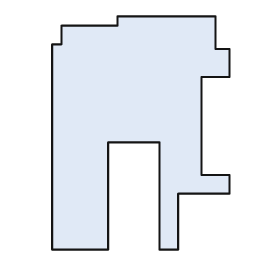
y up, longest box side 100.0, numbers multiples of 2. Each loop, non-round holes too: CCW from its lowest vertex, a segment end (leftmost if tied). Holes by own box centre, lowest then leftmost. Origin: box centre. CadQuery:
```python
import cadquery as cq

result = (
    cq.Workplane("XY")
    .moveTo(-38.0, -50.0)
    .lineTo(-14.0, -50.0)
    .lineTo(-14.0, -4.0)
    .lineTo(8.0, -4.0)
    .lineTo(8.0, -50.0)
    .lineTo(16.0, -50.0)
    .lineTo(16.0, -26.0)
    .lineTo(38.0, -26.0)
    .lineTo(38.0, -18.0)
    .lineTo(26.0, -18.0)
    .lineTo(26.0, 24.0)
    .lineTo(38.0, 24.0)
    .lineTo(38.0, 36.0)
    .lineTo(32.0, 36.0)
    .lineTo(32.0, 50.0)
    .lineTo(-10.0, 50.0)
    .lineTo(-10.0, 46.0)
    .lineTo(-34.0, 46.0)
    .lineTo(-34.0, 38.0)
    .lineTo(-38.0, 38.0)
    .close()
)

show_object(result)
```